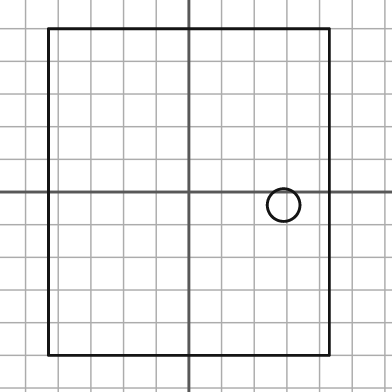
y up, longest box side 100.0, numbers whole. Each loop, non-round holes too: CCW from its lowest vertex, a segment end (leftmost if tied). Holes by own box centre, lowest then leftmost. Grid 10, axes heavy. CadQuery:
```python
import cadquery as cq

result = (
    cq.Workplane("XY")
    .moveTo(-43.0, -50.0)
    .lineTo(43.0, -50.0)
    .lineTo(43.0, 50.0)
    .lineTo(-43.0, 50.0)
    .close()
    .moveTo(29.0, -4.0)
    .circle(5.0)
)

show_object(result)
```